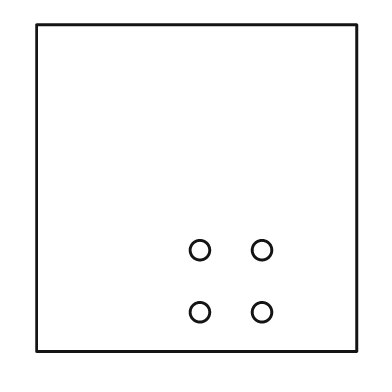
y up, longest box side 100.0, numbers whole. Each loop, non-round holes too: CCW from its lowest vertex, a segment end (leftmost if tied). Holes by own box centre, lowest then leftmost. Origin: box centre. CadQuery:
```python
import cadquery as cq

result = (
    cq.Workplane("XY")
    .moveTo(-49.0, -50.0)
    .lineTo(49.0, -50.0)
    .lineTo(49.0, 50.0)
    .lineTo(-49.0, 50.0)
    .close()
    .moveTo(1.0, -38.0)
    .circle(3.0)
    .moveTo(20.0, -38.0)
    .circle(3.0)
    .moveTo(1.0, -19.0)
    .circle(3.0)
    .moveTo(20.0, -19.0)
    .circle(3.0)
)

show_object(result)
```